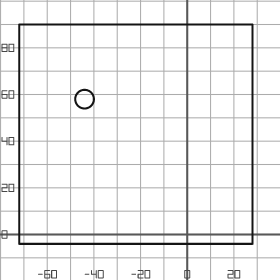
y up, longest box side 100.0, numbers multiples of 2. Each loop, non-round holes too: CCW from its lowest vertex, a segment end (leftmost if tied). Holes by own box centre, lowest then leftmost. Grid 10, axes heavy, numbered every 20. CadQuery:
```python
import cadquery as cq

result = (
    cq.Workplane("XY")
    .moveTo(-72.0, -4.0)
    .lineTo(28.0, -4.0)
    .lineTo(28.0, 90.0)
    .lineTo(-72.0, 90.0)
    .close()
    .moveTo(-44.0, 58.0)
    .circle(4.0)
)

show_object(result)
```